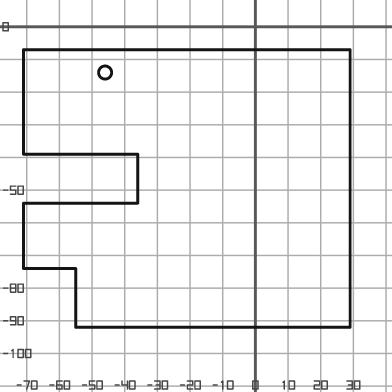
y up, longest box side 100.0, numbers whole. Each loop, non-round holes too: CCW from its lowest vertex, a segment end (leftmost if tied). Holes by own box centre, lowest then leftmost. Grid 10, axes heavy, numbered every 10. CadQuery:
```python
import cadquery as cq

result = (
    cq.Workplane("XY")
    .moveTo(-55.0, -92.0)
    .lineTo(29.0, -92.0)
    .lineTo(29.0, -7.0)
    .lineTo(-71.0, -7.0)
    .lineTo(-71.0, -39.0)
    .lineTo(-36.0, -39.0)
    .lineTo(-36.0, -54.0)
    .lineTo(-71.0, -54.0)
    .lineTo(-71.0, -74.0)
    .lineTo(-55.0, -74.0)
    .close()
    .moveTo(-46.0, -14.0)
    .circle(2.0)
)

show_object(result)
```